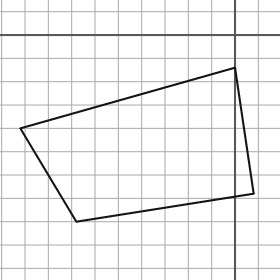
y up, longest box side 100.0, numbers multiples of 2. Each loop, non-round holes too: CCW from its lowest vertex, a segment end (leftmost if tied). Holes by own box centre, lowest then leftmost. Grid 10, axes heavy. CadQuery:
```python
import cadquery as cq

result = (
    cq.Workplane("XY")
    .moveTo(-68.0, -80.0)
    .lineTo(8.0, -68.0)
    .lineTo(0.0, -14.0)
    .lineTo(-92.0, -40.0)
    .close()
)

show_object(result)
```